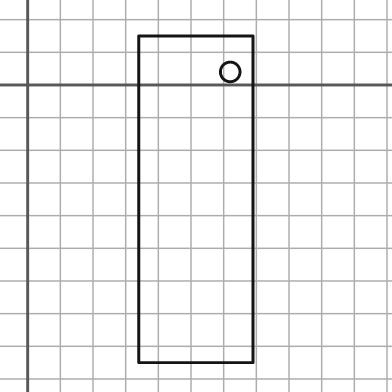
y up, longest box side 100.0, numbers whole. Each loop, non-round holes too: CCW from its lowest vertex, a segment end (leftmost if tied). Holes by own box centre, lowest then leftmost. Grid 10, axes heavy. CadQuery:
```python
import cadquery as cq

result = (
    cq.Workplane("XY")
    .moveTo(34.0, -85.0)
    .lineTo(69.0, -85.0)
    .lineTo(69.0, 15.0)
    .lineTo(34.0, 15.0)
    .close()
    .moveTo(62.0, 4.0)
    .circle(3.0)
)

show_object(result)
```